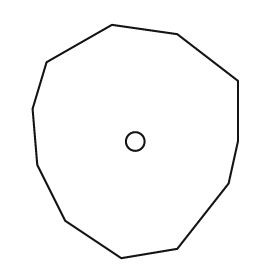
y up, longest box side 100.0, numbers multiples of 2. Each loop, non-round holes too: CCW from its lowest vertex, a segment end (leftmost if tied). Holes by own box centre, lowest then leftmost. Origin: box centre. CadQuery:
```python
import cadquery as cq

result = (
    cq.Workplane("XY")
    .moveTo(-6.0, -50.0)
    .lineTo(18.0, -46.0)
    .lineTo(40.0, -18.0)
    .lineTo(44.0, 0.0)
    .lineTo(44.0, 26.0)
    .lineTo(18.0, 46.0)
    .lineTo(-10.0, 50.0)
    .lineTo(-38.0, 34.0)
    .lineTo(-44.0, 14.0)
    .lineTo(-42.0, -10.0)
    .lineTo(-30.0, -34.0)
    .close()
    .moveTo(0.0, 0.0)
    .circle(4.0)
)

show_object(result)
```